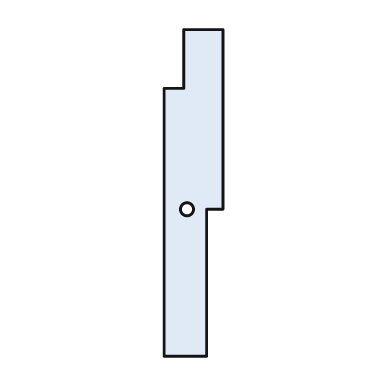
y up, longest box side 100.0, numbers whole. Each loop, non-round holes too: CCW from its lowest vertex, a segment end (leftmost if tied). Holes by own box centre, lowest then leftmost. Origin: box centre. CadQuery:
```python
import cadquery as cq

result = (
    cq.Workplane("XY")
    .moveTo(-9.0, -50.0)
    .lineTo(4.0, -50.0)
    .lineTo(4.0, -5.0)
    .lineTo(9.0, -5.0)
    .lineTo(9.0, 50.0)
    .lineTo(-3.0, 50.0)
    .lineTo(-3.0, 32.0)
    .lineTo(-9.0, 32.0)
    .close()
    .moveTo(-2.0, -5.0)
    .circle(2.0)
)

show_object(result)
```